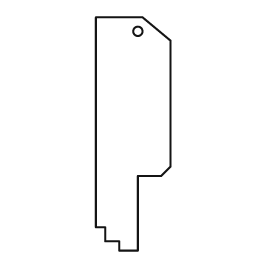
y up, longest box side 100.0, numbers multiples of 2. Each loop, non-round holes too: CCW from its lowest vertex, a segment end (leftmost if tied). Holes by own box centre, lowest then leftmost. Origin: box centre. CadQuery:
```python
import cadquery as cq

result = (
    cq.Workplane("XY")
    .moveTo(-6.0, -50.0)
    .lineTo(2.0, -50.0)
    .lineTo(2.0, -18.0)
    .lineTo(12.0, -18.0)
    .lineTo(16.0, -14.0)
    .lineTo(16.0, 40.0)
    .lineTo(4.0, 50.0)
    .lineTo(-16.0, 50.0)
    .lineTo(-16.0, -40.0)
    .lineTo(-12.0, -40.0)
    .lineTo(-12.0, -46.0)
    .lineTo(-6.0, -46.0)
    .close()
    .moveTo(2.0, 44.0)
    .circle(2.0)
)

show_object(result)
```